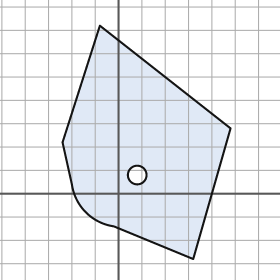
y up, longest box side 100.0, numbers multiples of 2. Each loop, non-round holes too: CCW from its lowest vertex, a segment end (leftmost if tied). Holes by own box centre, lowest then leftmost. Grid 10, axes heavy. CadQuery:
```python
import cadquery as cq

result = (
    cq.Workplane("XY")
    .moveTo(32.0, -28.0)
    .lineTo(48.0, 28.0)
    .lineTo(-8.0, 72.0)
    .lineTo(-24.0, 22.0)
    .lineTo(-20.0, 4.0)
    .threePointArc((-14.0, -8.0), (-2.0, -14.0))
    .close()
    .moveTo(8.0, 8.0)
    .circle(4.0)
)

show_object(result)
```